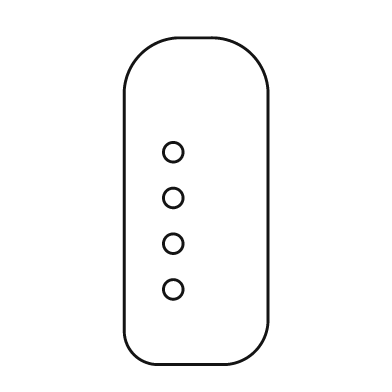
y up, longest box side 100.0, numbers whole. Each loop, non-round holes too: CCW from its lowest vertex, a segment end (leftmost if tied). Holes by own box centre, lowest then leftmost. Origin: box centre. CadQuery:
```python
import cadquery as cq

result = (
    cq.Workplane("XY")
    .moveTo(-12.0, -50.0)
    .lineTo(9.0, -50.0)
    .threePointArc((18.0, -46.0), (22.0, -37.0))
    .lineTo(22.0, 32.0)
    .threePointArc((17.0, 45.0), (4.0, 50.0))
    .lineTo(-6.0, 50.0)
    .threePointArc((-17.0, 45.0), (-22.0, 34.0))
    .lineTo(-22.0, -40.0)
    .threePointArc((-19.0, -47.0), (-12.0, -50.0))
    .close()
    .moveTo(-7.0, -27.0)
    .circle(3.0)
    .moveTo(-7.0, -13.0)
    .circle(3.0)
    .moveTo(-7.0, 1.0)
    .circle(3.0)
    .moveTo(-7.0, 15.0)
    .circle(3.0)
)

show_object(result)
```